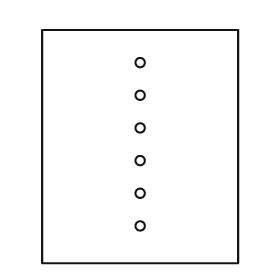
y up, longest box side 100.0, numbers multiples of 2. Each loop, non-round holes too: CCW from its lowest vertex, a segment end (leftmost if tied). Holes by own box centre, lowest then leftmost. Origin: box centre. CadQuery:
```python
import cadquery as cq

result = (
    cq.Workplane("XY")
    .moveTo(-42.0, -50.0)
    .lineTo(42.0, -50.0)
    .lineTo(42.0, 50.0)
    .lineTo(-42.0, 50.0)
    .close()
    .moveTo(0.0, -34.0)
    .circle(2.0)
    .moveTo(0.0, -20.0)
    .circle(2.0)
    .moveTo(0.0, -6.0)
    .circle(2.0)
    .moveTo(0.0, 8.0)
    .circle(2.0)
    .moveTo(0.0, 22.0)
    .circle(2.0)
    .moveTo(0.0, 36.0)
    .circle(2.0)
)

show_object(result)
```